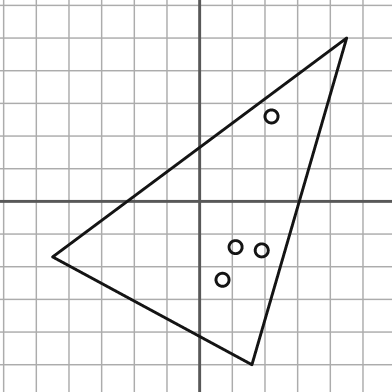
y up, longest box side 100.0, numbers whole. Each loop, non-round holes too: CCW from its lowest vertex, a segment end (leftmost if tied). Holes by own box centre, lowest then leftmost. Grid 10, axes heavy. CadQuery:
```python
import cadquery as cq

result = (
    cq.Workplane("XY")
    .moveTo(16.0, -50.0)
    .lineTo(45.0, 50.0)
    .lineTo(-45.0, -17.0)
    .close()
    .moveTo(7.0, -24.0)
    .circle(2.0)
    .moveTo(19.0, -15.0)
    .circle(2.0)
    .moveTo(11.0, -14.0)
    .circle(2.0)
    .moveTo(22.0, 26.0)
    .circle(2.0)
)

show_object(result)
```